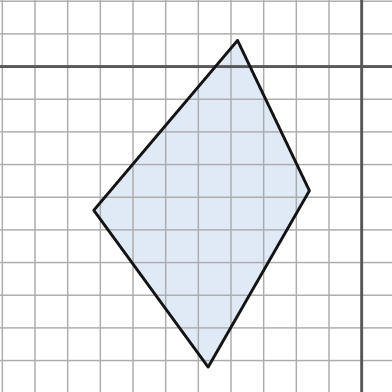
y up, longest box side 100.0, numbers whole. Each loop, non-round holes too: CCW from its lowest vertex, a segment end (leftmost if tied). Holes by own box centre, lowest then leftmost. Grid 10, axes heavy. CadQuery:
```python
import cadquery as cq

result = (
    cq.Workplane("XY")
    .moveTo(-47.0, -92.0)
    .lineTo(-16.0, -38.0)
    .lineTo(-38.0, 8.0)
    .lineTo(-82.0, -44.0)
    .close()
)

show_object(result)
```